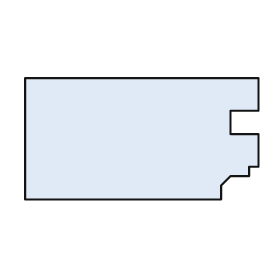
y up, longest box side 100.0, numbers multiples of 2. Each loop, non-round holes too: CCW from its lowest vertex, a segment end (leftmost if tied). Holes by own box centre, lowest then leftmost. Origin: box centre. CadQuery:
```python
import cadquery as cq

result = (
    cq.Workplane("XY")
    .moveTo(-50.0, -26.0)
    .lineTo(34.0, -26.0)
    .lineTo(34.0, -20.0)
    .lineTo(38.0, -16.0)
    .lineTo(46.0, -16.0)
    .lineTo(46.0, -12.0)
    .lineTo(50.0, -12.0)
    .lineTo(50.0, 2.0)
    .lineTo(38.0, 2.0)
    .lineTo(38.0, 12.0)
    .lineTo(50.0, 12.0)
    .lineTo(50.0, 26.0)
    .lineTo(-50.0, 26.0)
    .close()
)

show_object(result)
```